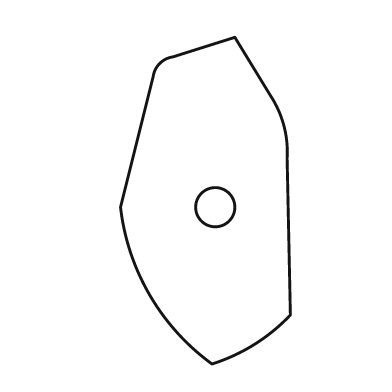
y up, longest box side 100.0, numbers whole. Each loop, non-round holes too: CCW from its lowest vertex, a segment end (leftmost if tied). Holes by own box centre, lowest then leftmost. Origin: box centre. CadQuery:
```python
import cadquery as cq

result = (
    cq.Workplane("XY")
    .moveTo(2.0, -50.0)
    .threePointArc((15.0, -44.0), (26.0, -35.0))
    .lineTo(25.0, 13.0)
    .threePointArc((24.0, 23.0), (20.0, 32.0))
    .lineTo(9.0, 50.0)
    .lineTo(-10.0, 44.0)
    .threePointArc((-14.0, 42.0), (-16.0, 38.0))
    .lineTo(-26.0, -2.0)
    .threePointArc((-17.0, -29.0), (2.0, -50.0))
    .close()
    .moveTo(3.0, -2.0)
    .circle(6.0)
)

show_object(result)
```